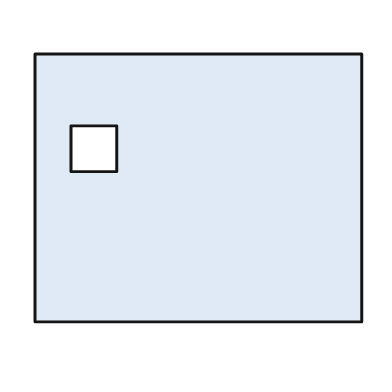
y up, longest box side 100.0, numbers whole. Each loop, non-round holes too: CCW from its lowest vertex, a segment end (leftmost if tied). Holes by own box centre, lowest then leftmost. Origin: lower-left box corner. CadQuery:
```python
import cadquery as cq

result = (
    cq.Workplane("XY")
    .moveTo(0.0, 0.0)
    .lineTo(100.0, 0.0)
    .lineTo(100.0, 82.0)
    .lineTo(0.0, 82.0)
    .close()
    .moveTo(11.0, 46.0)
    .lineTo(25.0, 46.0)
    .lineTo(25.0, 60.0)
    .lineTo(11.0, 60.0)
    .close()
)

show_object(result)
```